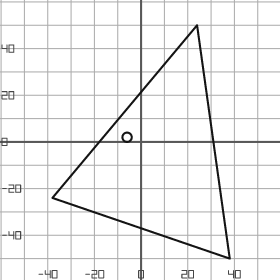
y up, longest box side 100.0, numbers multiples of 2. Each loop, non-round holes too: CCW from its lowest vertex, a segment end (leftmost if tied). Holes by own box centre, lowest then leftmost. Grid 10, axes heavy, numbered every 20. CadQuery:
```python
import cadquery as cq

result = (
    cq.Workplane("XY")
    .moveTo(38.0, -50.0)
    .lineTo(24.0, 50.0)
    .lineTo(-38.0, -24.0)
    .close()
    .moveTo(-6.0, 2.0)
    .circle(2.0)
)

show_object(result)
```